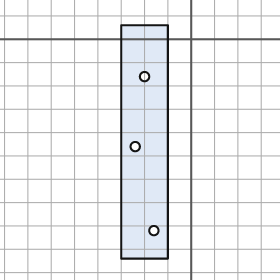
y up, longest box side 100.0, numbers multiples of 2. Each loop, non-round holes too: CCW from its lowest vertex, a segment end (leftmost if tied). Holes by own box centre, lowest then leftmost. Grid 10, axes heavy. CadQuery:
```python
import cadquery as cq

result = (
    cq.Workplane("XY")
    .moveTo(-30.0, -94.0)
    .lineTo(-10.0, -94.0)
    .lineTo(-10.0, 6.0)
    .lineTo(-30.0, 6.0)
    .close()
    .moveTo(-16.0, -82.0)
    .circle(2.0)
    .moveTo(-24.0, -46.0)
    .circle(2.0)
    .moveTo(-20.0, -16.0)
    .circle(2.0)
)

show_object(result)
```